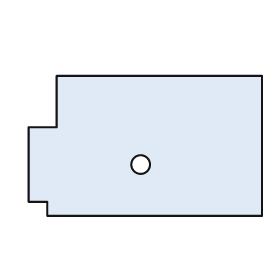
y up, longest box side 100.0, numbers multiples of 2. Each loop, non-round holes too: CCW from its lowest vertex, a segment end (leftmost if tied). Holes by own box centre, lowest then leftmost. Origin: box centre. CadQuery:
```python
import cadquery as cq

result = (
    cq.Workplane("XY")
    .moveTo(-42.0, -30.0)
    .lineTo(50.0, -30.0)
    .lineTo(50.0, 30.0)
    .lineTo(-38.0, 30.0)
    .lineTo(-38.0, 8.0)
    .lineTo(-50.0, 8.0)
    .lineTo(-50.0, -24.0)
    .lineTo(-42.0, -24.0)
    .close()
    .moveTo(-2.0, -8.0)
    .circle(4.0)
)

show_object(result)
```